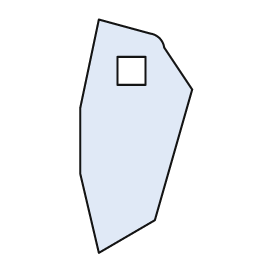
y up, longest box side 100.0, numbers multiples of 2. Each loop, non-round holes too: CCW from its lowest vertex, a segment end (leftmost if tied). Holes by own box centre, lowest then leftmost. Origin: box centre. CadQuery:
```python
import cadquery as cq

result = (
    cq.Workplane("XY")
    .moveTo(-16.0, -50.0)
    .lineTo(8.0, -36.0)
    .lineTo(24.0, 20.0)
    .lineTo(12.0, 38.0)
    .threePointArc((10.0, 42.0), (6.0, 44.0))
    .lineTo(-16.0, 50.0)
    .lineTo(-24.0, 12.0)
    .lineTo(-24.0, -16.0)
    .close()
    .moveTo(-8.0, 22.0)
    .lineTo(4.0, 22.0)
    .lineTo(4.0, 34.0)
    .lineTo(-8.0, 34.0)
    .close()
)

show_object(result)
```